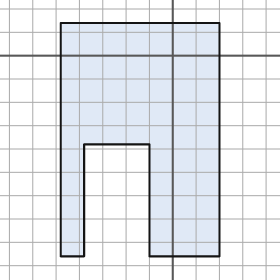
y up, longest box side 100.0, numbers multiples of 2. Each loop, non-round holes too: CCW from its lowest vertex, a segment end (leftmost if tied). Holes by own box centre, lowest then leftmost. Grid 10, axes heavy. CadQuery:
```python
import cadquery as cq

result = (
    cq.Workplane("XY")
    .moveTo(-48.0, -86.0)
    .lineTo(-38.0, -86.0)
    .lineTo(-38.0, -38.0)
    .lineTo(-10.0, -38.0)
    .lineTo(-10.0, -86.0)
    .lineTo(20.0, -86.0)
    .lineTo(20.0, 14.0)
    .lineTo(-48.0, 14.0)
    .close()
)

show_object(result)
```